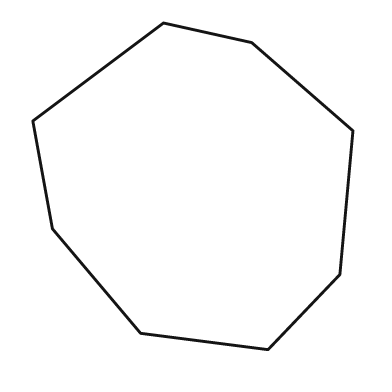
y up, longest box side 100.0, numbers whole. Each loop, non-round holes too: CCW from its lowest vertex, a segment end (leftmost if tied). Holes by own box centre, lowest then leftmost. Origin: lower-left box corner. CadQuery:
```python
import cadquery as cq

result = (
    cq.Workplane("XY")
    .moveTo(72.0, 0.0)
    .lineTo(94.0, 23.0)
    .lineTo(98.0, 67.0)
    .lineTo(67.0, 94.0)
    .lineTo(40.0, 100.0)
    .lineTo(0.0, 70.0)
    .lineTo(6.0, 37.0)
    .lineTo(33.0, 5.0)
    .close()
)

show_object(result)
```